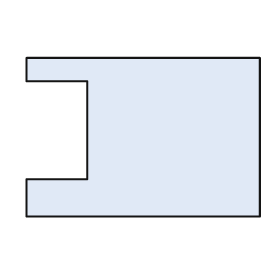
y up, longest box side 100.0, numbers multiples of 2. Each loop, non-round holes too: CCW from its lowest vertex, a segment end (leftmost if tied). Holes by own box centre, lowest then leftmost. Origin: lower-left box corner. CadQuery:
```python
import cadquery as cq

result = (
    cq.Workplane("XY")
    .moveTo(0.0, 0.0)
    .lineTo(100.0, 0.0)
    .lineTo(100.0, 68.0)
    .lineTo(0.0, 68.0)
    .lineTo(0.0, 58.0)
    .lineTo(26.0, 58.0)
    .lineTo(26.0, 16.0)
    .lineTo(0.0, 16.0)
    .close()
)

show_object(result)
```